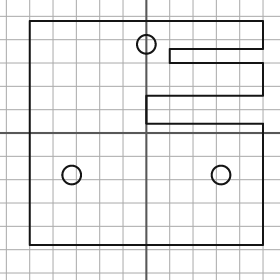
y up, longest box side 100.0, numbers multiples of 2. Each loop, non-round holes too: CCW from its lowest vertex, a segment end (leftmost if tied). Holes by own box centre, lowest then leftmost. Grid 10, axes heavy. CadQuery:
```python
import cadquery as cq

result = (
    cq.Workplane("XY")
    .moveTo(-50.0, -48.0)
    .lineTo(50.0, -48.0)
    .lineTo(50.0, 4.0)
    .lineTo(0.0, 4.0)
    .lineTo(0.0, 16.0)
    .lineTo(50.0, 16.0)
    .lineTo(50.0, 30.0)
    .lineTo(10.0, 30.0)
    .lineTo(10.0, 36.0)
    .lineTo(50.0, 36.0)
    .lineTo(50.0, 48.0)
    .lineTo(-50.0, 48.0)
    .close()
    .moveTo(-32.0, -18.0)
    .circle(4.0)
    .moveTo(32.0, -18.0)
    .circle(4.0)
    .moveTo(0.0, 38.0)
    .circle(4.0)
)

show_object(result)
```